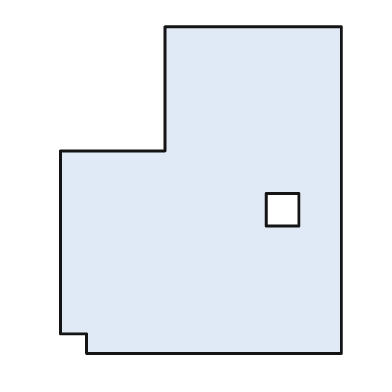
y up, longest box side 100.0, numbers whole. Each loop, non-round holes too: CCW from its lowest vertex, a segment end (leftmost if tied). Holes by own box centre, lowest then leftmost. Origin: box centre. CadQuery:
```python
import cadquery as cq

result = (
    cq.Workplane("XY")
    .moveTo(-35.0, -50.0)
    .lineTo(43.0, -50.0)
    .lineTo(43.0, 50.0)
    .lineTo(-11.0, 50.0)
    .lineTo(-11.0, 12.0)
    .lineTo(-43.0, 12.0)
    .lineTo(-43.0, -44.0)
    .lineTo(-35.0, -44.0)
    .close()
    .moveTo(20.0, -11.0)
    .lineTo(30.0, -11.0)
    .lineTo(30.0, -1.0)
    .lineTo(20.0, -1.0)
    .close()
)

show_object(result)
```